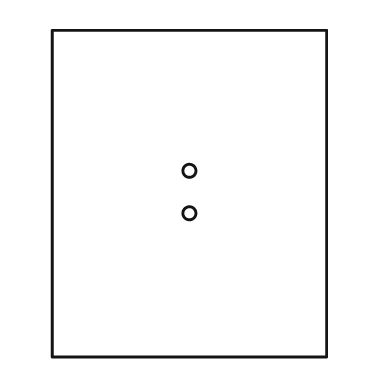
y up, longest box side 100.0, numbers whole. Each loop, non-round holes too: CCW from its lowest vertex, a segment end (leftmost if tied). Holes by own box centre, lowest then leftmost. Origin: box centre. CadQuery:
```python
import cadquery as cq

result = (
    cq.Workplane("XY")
    .moveTo(-42.0, -50.0)
    .lineTo(42.0, -50.0)
    .lineTo(42.0, 50.0)
    .lineTo(-42.0, 50.0)
    .close()
    .moveTo(0.0, -6.0)
    .circle(2.0)
    .moveTo(0.0, 7.0)
    .circle(2.0)
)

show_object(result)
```